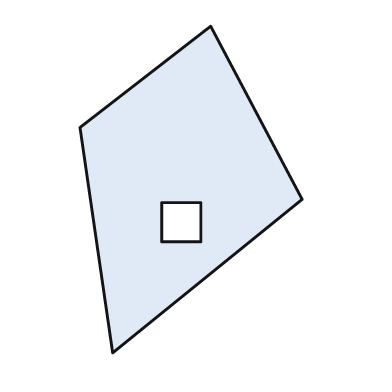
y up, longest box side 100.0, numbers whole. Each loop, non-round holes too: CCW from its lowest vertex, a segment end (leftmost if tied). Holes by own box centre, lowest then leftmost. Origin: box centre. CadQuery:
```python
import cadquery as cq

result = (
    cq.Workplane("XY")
    .moveTo(-24.0, -50.0)
    .lineTo(34.0, -3.0)
    .lineTo(6.0, 50.0)
    .lineTo(-34.0, 19.0)
    .close()
    .moveTo(-9.0, -16.0)
    .lineTo(3.0, -16.0)
    .lineTo(3.0, -4.0)
    .lineTo(-9.0, -4.0)
    .close()
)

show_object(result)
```